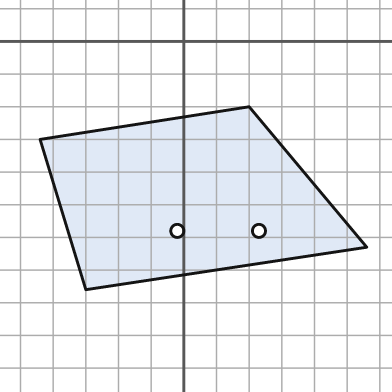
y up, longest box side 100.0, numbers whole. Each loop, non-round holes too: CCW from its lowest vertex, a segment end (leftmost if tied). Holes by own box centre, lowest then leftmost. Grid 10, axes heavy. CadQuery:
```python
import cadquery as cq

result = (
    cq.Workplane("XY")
    .moveTo(-30.0, -76.0)
    .lineTo(56.0, -63.0)
    .lineTo(20.0, -20.0)
    .lineTo(-44.0, -30.0)
    .close()
    .moveTo(-2.0, -58.0)
    .circle(2.0)
    .moveTo(23.0, -58.0)
    .circle(2.0)
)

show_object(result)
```